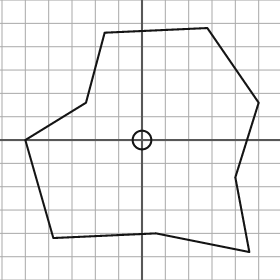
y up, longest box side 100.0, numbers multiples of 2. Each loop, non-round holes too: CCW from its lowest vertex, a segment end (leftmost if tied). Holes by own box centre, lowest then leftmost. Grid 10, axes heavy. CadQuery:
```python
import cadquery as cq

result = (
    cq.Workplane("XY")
    .moveTo(46.0, -48.0)
    .lineTo(40.0, -16.0)
    .lineTo(50.0, 16.0)
    .lineTo(28.0, 48.0)
    .lineTo(-16.0, 46.0)
    .lineTo(-24.0, 16.0)
    .lineTo(-50.0, 0.0)
    .lineTo(-38.0, -42.0)
    .lineTo(6.0, -40.0)
    .close()
    .moveTo(0.0, 0.0)
    .circle(4.0)
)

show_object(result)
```